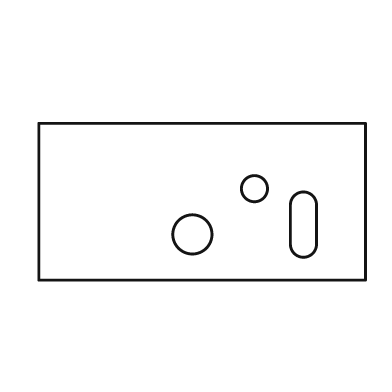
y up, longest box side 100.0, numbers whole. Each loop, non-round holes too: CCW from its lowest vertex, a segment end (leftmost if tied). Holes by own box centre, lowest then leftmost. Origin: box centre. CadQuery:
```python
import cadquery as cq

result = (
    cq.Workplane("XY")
    .moveTo(-50.0, -24.0)
    .lineTo(50.0, -24.0)
    .lineTo(50.0, 24.0)
    .lineTo(-50.0, 24.0)
    .close()
    .moveTo(-3.0, -10.0)
    .circle(6.0)
    .moveTo(27.0, -13.0)
    .threePointArc((31.0, -17.0), (35.0, -13.0))
    .lineTo(35.0, -1.0)
    .threePointArc((31.0, 3.0), (27.0, -1.0))
    .close()
    .moveTo(16.0, 4.0)
    .circle(4.0)
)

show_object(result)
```